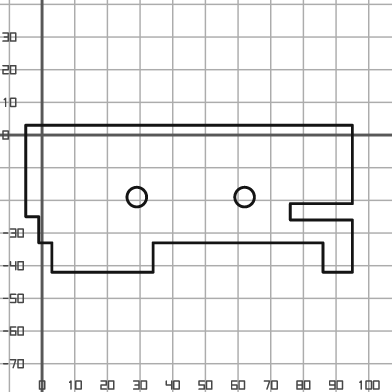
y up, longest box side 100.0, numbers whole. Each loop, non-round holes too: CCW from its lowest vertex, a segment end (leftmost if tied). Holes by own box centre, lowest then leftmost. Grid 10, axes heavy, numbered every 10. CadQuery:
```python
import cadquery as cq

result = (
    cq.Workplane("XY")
    .moveTo(3.0, -42.0)
    .lineTo(34.0, -42.0)
    .lineTo(34.0, -33.0)
    .lineTo(86.0, -33.0)
    .lineTo(86.0, -42.0)
    .lineTo(95.0, -42.0)
    .lineTo(95.0, -26.0)
    .lineTo(76.0, -26.0)
    .lineTo(76.0, -21.0)
    .lineTo(95.0, -21.0)
    .lineTo(95.0, 3.0)
    .lineTo(-5.0, 3.0)
    .lineTo(-5.0, -25.0)
    .lineTo(-1.0, -25.0)
    .lineTo(-1.0, -33.0)
    .lineTo(3.0, -33.0)
    .close()
    .moveTo(29.0, -19.0)
    .circle(3.0)
    .moveTo(62.0, -19.0)
    .circle(3.0)
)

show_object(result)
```